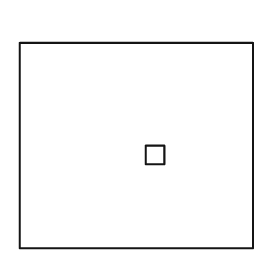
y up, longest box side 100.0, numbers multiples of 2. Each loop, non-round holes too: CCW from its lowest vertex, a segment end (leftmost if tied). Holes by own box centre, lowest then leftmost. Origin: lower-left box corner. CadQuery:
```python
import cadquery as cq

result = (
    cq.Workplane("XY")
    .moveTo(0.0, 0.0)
    .lineTo(100.0, 0.0)
    .lineTo(100.0, 88.0)
    .lineTo(0.0, 88.0)
    .close()
    .moveTo(54.0, 36.0)
    .lineTo(62.0, 36.0)
    .lineTo(62.0, 44.0)
    .lineTo(54.0, 44.0)
    .close()
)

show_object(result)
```